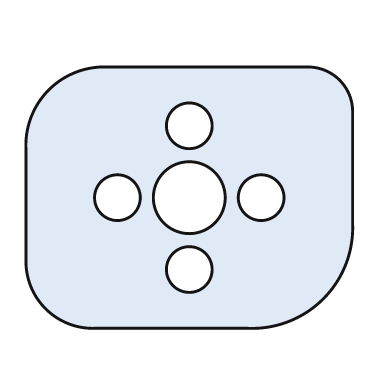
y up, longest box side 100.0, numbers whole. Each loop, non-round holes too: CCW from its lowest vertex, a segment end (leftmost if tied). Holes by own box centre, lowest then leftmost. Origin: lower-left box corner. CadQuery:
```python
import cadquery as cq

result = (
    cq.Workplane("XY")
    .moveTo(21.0, 0.0)
    .lineTo(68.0, 0.0)
    .threePointArc((91.0, 9.0), (100.0, 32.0))
    .lineTo(100.0, 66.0)
    .threePointArc((96.0, 76.0), (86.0, 80.0))
    .lineTo(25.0, 80.0)
    .threePointArc((7.0, 73.0), (0.0, 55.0))
    .lineTo(0.0, 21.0)
    .threePointArc((6.0, 6.0), (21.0, 0.0))
    .close()
    .moveTo(50.0, 18.0)
    .circle(7.0)
    .moveTo(28.0, 40.0)
    .circle(7.0)
    .moveTo(50.0, 40.0)
    .circle(11.0)
    .moveTo(72.0, 40.0)
    .circle(7.0)
    .moveTo(50.0, 62.0)
    .circle(7.0)
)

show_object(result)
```